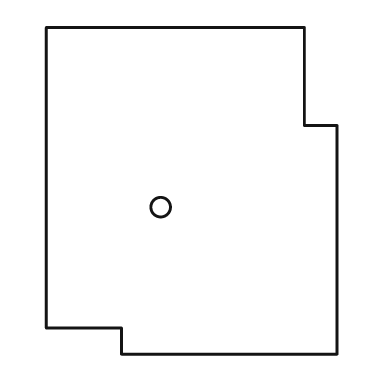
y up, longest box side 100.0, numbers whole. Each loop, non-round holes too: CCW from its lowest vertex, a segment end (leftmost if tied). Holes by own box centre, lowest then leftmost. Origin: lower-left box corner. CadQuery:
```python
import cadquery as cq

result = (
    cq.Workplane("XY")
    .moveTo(23.0, 0.0)
    .lineTo(89.0, 0.0)
    .lineTo(89.0, 70.0)
    .lineTo(79.0, 70.0)
    .lineTo(79.0, 100.0)
    .lineTo(0.0, 100.0)
    .lineTo(0.0, 8.0)
    .lineTo(23.0, 8.0)
    .close()
    .moveTo(35.0, 45.0)
    .circle(3.0)
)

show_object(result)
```